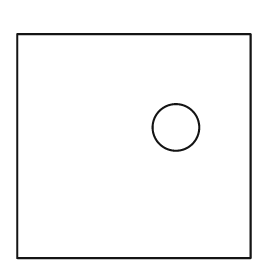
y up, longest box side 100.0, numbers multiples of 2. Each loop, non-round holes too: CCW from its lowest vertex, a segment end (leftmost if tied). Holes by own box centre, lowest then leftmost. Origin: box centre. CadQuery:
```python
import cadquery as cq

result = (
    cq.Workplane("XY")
    .moveTo(-50.0, -48.0)
    .lineTo(50.0, -48.0)
    .lineTo(50.0, 48.0)
    .lineTo(-50.0, 48.0)
    .close()
    .moveTo(18.0, 8.0)
    .circle(10.0)
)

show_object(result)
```